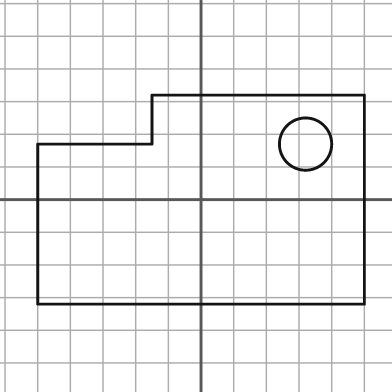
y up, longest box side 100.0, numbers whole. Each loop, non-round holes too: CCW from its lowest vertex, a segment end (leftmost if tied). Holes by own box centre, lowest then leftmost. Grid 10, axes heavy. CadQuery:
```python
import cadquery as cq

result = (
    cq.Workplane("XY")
    .moveTo(-50.0, -32.0)
    .lineTo(50.0, -32.0)
    .lineTo(50.0, 32.0)
    .lineTo(-15.0, 32.0)
    .lineTo(-15.0, 17.0)
    .lineTo(-50.0, 17.0)
    .close()
    .moveTo(32.0, 17.0)
    .circle(8.0)
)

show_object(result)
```